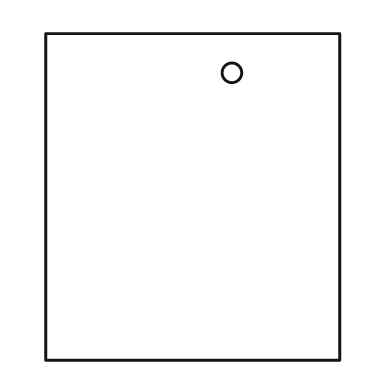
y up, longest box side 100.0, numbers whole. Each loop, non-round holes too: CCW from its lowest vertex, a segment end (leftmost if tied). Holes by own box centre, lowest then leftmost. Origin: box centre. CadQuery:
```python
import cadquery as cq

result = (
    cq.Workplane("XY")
    .moveTo(-45.0, -50.0)
    .lineTo(45.0, -50.0)
    .lineTo(45.0, 50.0)
    .lineTo(-45.0, 50.0)
    .close()
    .moveTo(12.0, 38.0)
    .circle(3.0)
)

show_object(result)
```